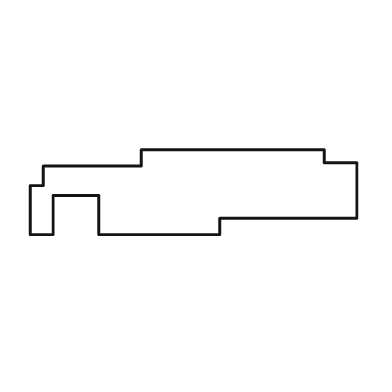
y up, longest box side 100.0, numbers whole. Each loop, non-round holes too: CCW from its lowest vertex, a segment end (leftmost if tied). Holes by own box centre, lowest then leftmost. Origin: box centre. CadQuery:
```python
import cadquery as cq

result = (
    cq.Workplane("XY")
    .moveTo(-50.0, -13.0)
    .lineTo(-43.0, -13.0)
    .lineTo(-43.0, -1.0)
    .lineTo(-29.0, -1.0)
    .lineTo(-29.0, -13.0)
    .lineTo(8.0, -13.0)
    .lineTo(8.0, -8.0)
    .lineTo(50.0, -8.0)
    .lineTo(50.0, 9.0)
    .lineTo(40.0, 9.0)
    .lineTo(40.0, 13.0)
    .lineTo(-16.0, 13.0)
    .lineTo(-16.0, 8.0)
    .lineTo(-46.0, 8.0)
    .lineTo(-46.0, 2.0)
    .lineTo(-50.0, 2.0)
    .close()
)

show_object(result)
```